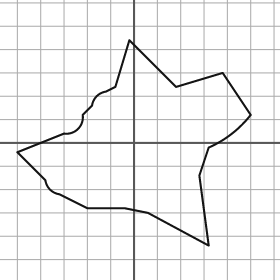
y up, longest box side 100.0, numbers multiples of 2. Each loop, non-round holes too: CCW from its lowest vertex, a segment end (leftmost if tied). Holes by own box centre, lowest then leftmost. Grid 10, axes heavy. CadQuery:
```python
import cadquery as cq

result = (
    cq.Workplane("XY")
    .moveTo(32.0, -44.0)
    .lineTo(28.0, -14.0)
    .lineTo(32.0, -2.0)
    .threePointArc((42.0, 4.0), (50.0, 12.0))
    .lineTo(38.0, 30.0)
    .lineTo(18.0, 24.0)
    .lineTo(-2.0, 44.0)
    .lineTo(-8.0, 24.0)
    .lineTo(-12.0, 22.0)
    .threePointArc((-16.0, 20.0), (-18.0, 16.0))
    .lineTo(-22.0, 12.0)
    .threePointArc((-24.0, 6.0), (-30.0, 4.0))
    .lineTo(-50.0, -4.0)
    .lineTo(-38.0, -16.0)
    .threePointArc((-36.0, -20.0), (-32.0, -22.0))
    .lineTo(-20.0, -28.0)
    .lineTo(-4.0, -28.0)
    .lineTo(6.0, -30.0)
    .close()
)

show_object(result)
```